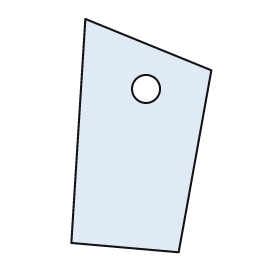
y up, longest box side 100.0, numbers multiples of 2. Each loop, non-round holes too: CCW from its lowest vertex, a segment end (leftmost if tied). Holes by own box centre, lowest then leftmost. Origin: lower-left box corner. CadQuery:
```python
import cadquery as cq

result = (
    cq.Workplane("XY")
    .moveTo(46.0, 0.0)
    .lineTo(60.0, 78.0)
    .lineTo(6.0, 100.0)
    .lineTo(0.0, 4.0)
    .close()
    .moveTo(32.0, 70.0)
    .circle(6.0)
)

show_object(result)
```